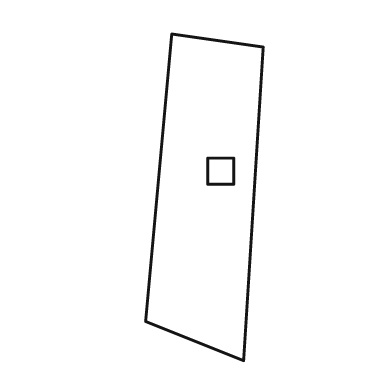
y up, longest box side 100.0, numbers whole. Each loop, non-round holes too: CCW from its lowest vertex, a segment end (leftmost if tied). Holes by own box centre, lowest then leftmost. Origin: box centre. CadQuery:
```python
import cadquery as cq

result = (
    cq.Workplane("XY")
    .moveTo(12.0, -50.0)
    .lineTo(18.0, 46.0)
    .lineTo(-10.0, 50.0)
    .lineTo(-18.0, -38.0)
    .close()
    .moveTo(1.0, 4.0)
    .lineTo(9.0, 4.0)
    .lineTo(9.0, 12.0)
    .lineTo(1.0, 12.0)
    .close()
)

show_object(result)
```